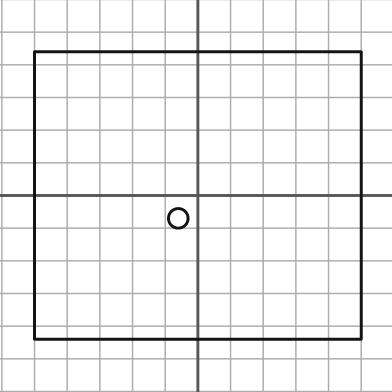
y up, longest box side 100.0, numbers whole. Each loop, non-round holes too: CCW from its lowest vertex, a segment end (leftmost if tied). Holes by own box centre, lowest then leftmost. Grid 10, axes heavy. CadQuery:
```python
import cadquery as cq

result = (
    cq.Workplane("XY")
    .moveTo(-50.0, -44.0)
    .lineTo(50.0, -44.0)
    .lineTo(50.0, 44.0)
    .lineTo(-50.0, 44.0)
    .close()
    .moveTo(-6.0, -7.0)
    .circle(3.0)
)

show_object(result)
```